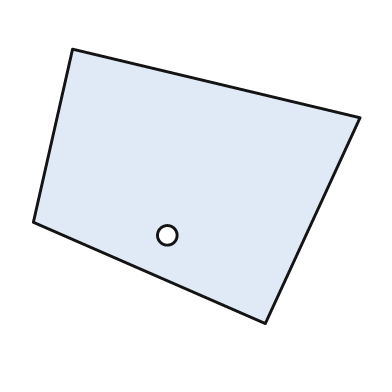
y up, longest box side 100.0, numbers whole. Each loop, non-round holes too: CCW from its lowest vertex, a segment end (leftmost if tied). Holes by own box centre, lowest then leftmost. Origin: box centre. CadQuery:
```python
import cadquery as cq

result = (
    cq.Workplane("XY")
    .moveTo(21.0, -42.0)
    .lineTo(50.0, 21.0)
    .lineTo(-38.0, 42.0)
    .lineTo(-50.0, -11.0)
    .close()
    .moveTo(-9.0, -15.0)
    .circle(3.0)
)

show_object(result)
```